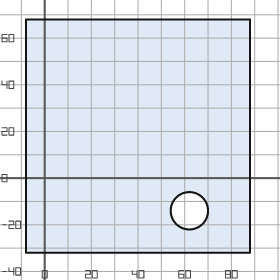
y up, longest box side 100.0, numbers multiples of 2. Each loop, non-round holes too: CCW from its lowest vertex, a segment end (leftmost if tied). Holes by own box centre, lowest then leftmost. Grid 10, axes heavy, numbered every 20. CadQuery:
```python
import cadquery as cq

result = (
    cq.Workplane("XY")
    .moveTo(-8.0, -32.0)
    .lineTo(88.0, -32.0)
    .lineTo(88.0, 68.0)
    .lineTo(-8.0, 68.0)
    .close()
    .moveTo(62.0, -14.0)
    .circle(8.0)
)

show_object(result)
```